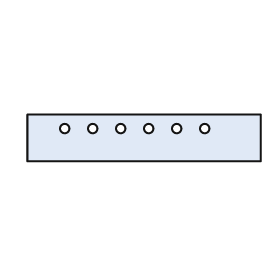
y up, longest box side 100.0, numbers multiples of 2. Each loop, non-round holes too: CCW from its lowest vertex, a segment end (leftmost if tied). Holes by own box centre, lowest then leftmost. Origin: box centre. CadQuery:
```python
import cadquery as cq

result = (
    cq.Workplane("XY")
    .moveTo(-50.0, -10.0)
    .lineTo(50.0, -10.0)
    .lineTo(50.0, 10.0)
    .lineTo(-50.0, 10.0)
    .close()
    .moveTo(-34.0, 4.0)
    .circle(2.0)
    .moveTo(-22.0, 4.0)
    .circle(2.0)
    .moveTo(-10.0, 4.0)
    .circle(2.0)
    .moveTo(2.0, 4.0)
    .circle(2.0)
    .moveTo(14.0, 4.0)
    .circle(2.0)
    .moveTo(26.0, 4.0)
    .circle(2.0)
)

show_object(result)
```